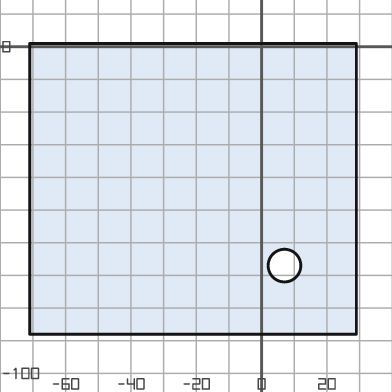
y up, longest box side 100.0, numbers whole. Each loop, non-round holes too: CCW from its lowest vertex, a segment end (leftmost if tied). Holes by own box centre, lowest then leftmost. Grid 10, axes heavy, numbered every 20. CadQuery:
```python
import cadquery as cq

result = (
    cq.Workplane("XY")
    .moveTo(-71.0, -88.0)
    .lineTo(29.0, -88.0)
    .lineTo(29.0, 1.0)
    .lineTo(-71.0, 1.0)
    .close()
    .moveTo(7.0, -67.0)
    .circle(5.0)
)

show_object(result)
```